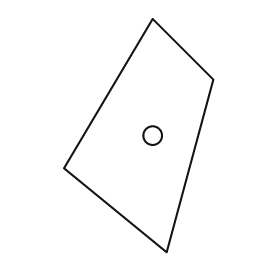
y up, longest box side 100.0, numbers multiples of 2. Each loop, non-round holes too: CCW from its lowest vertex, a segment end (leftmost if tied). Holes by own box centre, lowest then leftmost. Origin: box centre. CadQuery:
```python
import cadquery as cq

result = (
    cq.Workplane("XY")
    .moveTo(12.0, -50.0)
    .lineTo(32.0, 24.0)
    .lineTo(6.0, 50.0)
    .lineTo(-32.0, -14.0)
    .close()
    .moveTo(6.0, 0.0)
    .circle(4.0)
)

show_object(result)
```